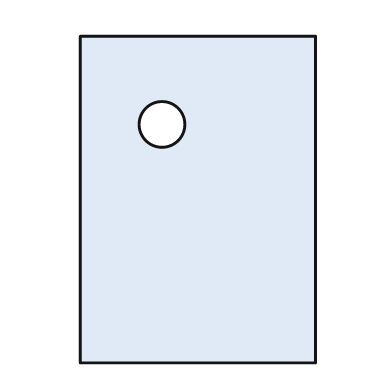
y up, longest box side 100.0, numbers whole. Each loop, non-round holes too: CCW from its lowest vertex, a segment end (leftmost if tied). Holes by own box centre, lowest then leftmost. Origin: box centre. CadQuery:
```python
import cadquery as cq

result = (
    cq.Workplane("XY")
    .moveTo(-36.0, -50.0)
    .lineTo(36.0, -50.0)
    .lineTo(36.0, 50.0)
    .lineTo(-36.0, 50.0)
    .close()
    .moveTo(-11.0, 23.0)
    .circle(7.0)
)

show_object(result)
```